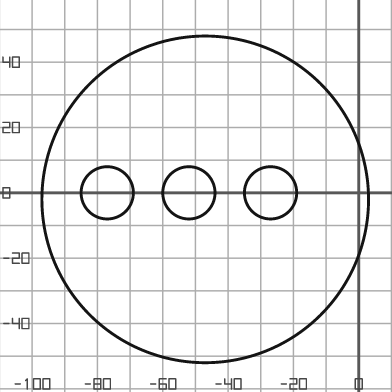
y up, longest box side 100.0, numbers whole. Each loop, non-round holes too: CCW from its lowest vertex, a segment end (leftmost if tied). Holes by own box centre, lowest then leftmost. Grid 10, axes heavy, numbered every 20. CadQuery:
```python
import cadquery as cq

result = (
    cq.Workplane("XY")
    .moveTo(-47.0, -2.0)
    .circle(50.0)
    .moveTo(-77.0, 0.0)
    .circle(8.0)
    .moveTo(-52.0, 0.0)
    .circle(8.0)
    .moveTo(-27.0, 0.0)
    .circle(8.0)
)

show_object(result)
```